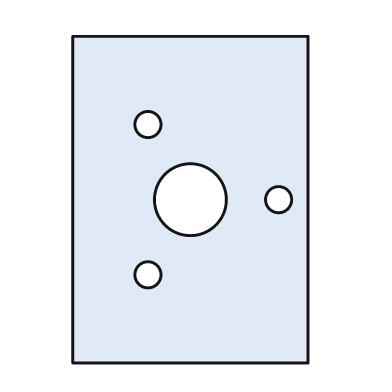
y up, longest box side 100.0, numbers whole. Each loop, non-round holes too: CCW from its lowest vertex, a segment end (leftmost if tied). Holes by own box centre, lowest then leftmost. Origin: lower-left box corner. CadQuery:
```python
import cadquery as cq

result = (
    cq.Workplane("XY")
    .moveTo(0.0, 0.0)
    .lineTo(72.0, 0.0)
    .lineTo(72.0, 100.0)
    .lineTo(0.0, 100.0)
    .close()
    .moveTo(23.0, 27.0)
    .circle(4.0)
    .moveTo(36.0, 50.0)
    .circle(11.0)
    .moveTo(63.0, 50.0)
    .circle(4.0)
    .moveTo(23.0, 73.0)
    .circle(4.0)
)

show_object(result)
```